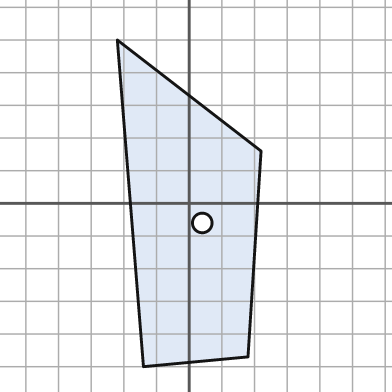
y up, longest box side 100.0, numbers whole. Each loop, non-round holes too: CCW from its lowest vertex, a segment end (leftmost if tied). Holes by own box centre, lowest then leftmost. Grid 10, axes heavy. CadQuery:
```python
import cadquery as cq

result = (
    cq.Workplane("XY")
    .moveTo(-14.0, -50.0)
    .lineTo(18.0, -47.0)
    .lineTo(22.0, 16.0)
    .lineTo(-22.0, 50.0)
    .close()
    .moveTo(4.0, -6.0)
    .circle(3.0)
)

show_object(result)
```